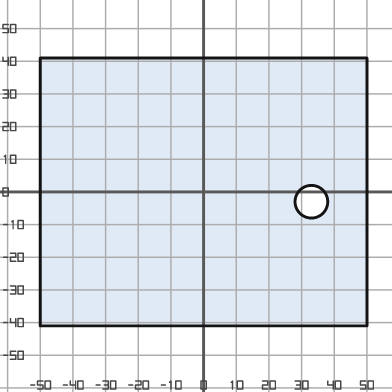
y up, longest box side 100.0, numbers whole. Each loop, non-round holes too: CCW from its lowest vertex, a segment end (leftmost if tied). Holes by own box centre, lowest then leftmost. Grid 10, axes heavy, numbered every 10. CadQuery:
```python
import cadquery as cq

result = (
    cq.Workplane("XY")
    .moveTo(-50.0, -41.0)
    .lineTo(50.0, -41.0)
    .lineTo(50.0, 41.0)
    .lineTo(-50.0, 41.0)
    .close()
    .moveTo(33.0, -3.0)
    .circle(5.0)
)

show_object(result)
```